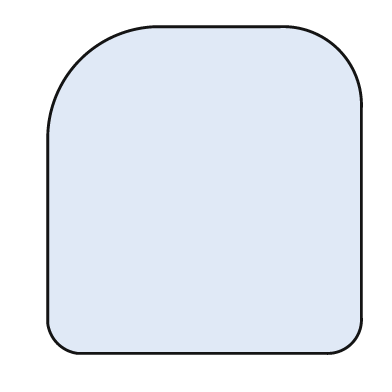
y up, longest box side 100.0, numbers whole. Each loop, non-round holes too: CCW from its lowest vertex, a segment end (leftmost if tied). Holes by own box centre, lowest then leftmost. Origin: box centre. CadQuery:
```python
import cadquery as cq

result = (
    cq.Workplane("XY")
    .moveTo(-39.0, -50.0)
    .lineTo(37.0, -50.0)
    .threePointArc((45.0, -47.0), (48.0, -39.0))
    .lineTo(48.0, 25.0)
    .threePointArc((41.0, 43.0), (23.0, 50.0))
    .lineTo(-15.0, 50.0)
    .threePointArc((-38.0, 40.0), (-48.0, 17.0))
    .lineTo(-48.0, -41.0)
    .threePointArc((-45.0, -47.0), (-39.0, -50.0))
    .close()
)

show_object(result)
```